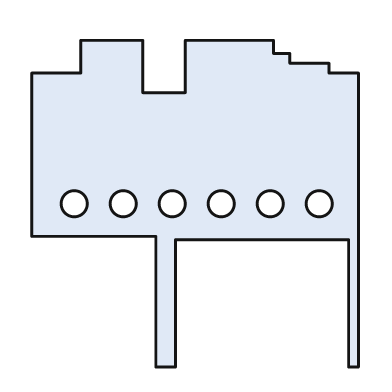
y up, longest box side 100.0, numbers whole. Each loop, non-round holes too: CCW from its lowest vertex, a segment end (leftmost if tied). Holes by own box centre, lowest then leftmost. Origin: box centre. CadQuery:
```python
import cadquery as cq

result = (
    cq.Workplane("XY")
    .moveTo(-12.0, -50.0)
    .lineTo(-6.0, -50.0)
    .lineTo(-6.0, -11.0)
    .lineTo(47.0, -11.0)
    .lineTo(47.0, -50.0)
    .lineTo(50.0, -50.0)
    .lineTo(50.0, 40.0)
    .lineTo(41.0, 40.0)
    .lineTo(41.0, 43.0)
    .lineTo(29.0, 43.0)
    .lineTo(29.0, 46.0)
    .lineTo(24.0, 46.0)
    .lineTo(24.0, 50.0)
    .lineTo(-3.0, 50.0)
    .lineTo(-3.0, 34.0)
    .lineTo(-16.0, 34.0)
    .lineTo(-16.0, 50.0)
    .lineTo(-35.0, 50.0)
    .lineTo(-35.0, 40.0)
    .lineTo(-50.0, 40.0)
    .lineTo(-50.0, -10.0)
    .lineTo(-12.0, -10.0)
    .close()
    .moveTo(-37.0, 0.0)
    .circle(4.0)
    .moveTo(-22.0, 0.0)
    .circle(4.0)
    .moveTo(-7.0, 0.0)
    .circle(4.0)
    .moveTo(8.0, 0.0)
    .circle(4.0)
    .moveTo(23.0, 0.0)
    .circle(4.0)
    .moveTo(38.0, 0.0)
    .circle(4.0)
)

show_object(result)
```